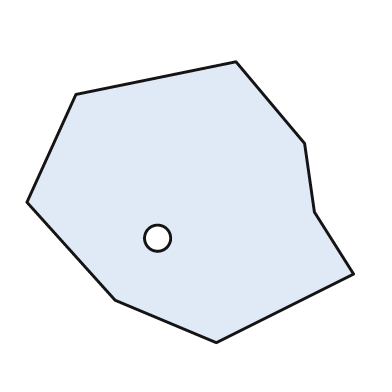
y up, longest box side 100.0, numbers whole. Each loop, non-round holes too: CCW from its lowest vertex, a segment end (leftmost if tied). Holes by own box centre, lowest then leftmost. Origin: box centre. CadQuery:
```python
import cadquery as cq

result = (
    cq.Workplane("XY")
    .moveTo(8.0, -43.0)
    .lineTo(50.0, -22.0)
    .lineTo(38.0, -3.0)
    .lineTo(35.0, 18.0)
    .lineTo(14.0, 43.0)
    .lineTo(-35.0, 33.0)
    .lineTo(-50.0, 0.0)
    .lineTo(-23.0, -30.0)
    .close()
    .moveTo(-10.0, -11.0)
    .circle(4.0)
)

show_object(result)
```